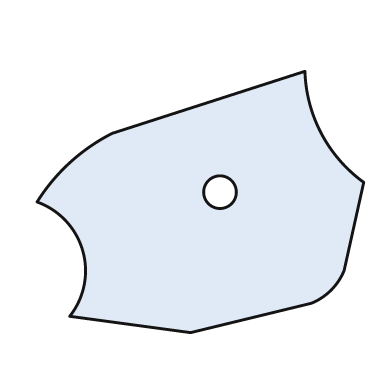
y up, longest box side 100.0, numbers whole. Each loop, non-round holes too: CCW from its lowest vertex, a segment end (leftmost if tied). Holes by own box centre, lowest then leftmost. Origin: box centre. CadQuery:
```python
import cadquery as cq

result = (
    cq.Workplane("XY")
    .moveTo(-3.0, -40.0)
    .lineTo(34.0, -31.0)
    .threePointArc((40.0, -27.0), (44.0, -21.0))
    .lineTo(50.0, 6.0)
    .threePointArc((37.0, 21.0), (32.0, 40.0))
    .lineTo(-27.0, 21.0)
    .threePointArc((-40.0, 12.0), (-50.0, 0.0))
    .threePointArc((-36.0, -15.0), (-40.0, -35.0))
    .close()
    .moveTo(6.0, 3.0)
    .circle(5.0)
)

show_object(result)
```